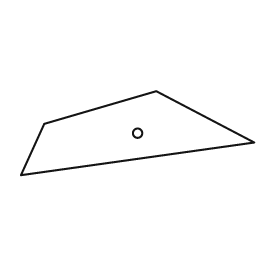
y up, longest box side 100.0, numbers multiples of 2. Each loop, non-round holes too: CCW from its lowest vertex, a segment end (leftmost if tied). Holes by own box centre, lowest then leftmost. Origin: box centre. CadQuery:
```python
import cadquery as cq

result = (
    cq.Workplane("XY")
    .moveTo(-50.0, -18.0)
    .lineTo(50.0, -4.0)
    .lineTo(8.0, 18.0)
    .lineTo(-40.0, 4.0)
    .close()
    .moveTo(0.0, 0.0)
    .circle(2.0)
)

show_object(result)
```